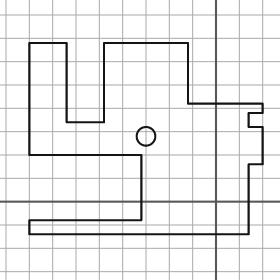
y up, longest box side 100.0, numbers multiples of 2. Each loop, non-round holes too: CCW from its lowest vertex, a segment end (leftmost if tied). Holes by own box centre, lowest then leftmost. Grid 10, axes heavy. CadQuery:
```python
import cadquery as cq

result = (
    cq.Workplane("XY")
    .moveTo(-80.0, -14.0)
    .lineTo(14.0, -14.0)
    .lineTo(14.0, 16.0)
    .lineTo(20.0, 16.0)
    .lineTo(20.0, 32.0)
    .lineTo(14.0, 32.0)
    .lineTo(14.0, 38.0)
    .lineTo(20.0, 38.0)
    .lineTo(20.0, 42.0)
    .lineTo(-12.0, 42.0)
    .lineTo(-12.0, 68.0)
    .lineTo(-48.0, 68.0)
    .lineTo(-48.0, 34.0)
    .lineTo(-64.0, 34.0)
    .lineTo(-64.0, 68.0)
    .lineTo(-80.0, 68.0)
    .lineTo(-80.0, 20.0)
    .lineTo(-32.0, 20.0)
    .lineTo(-32.0, -8.0)
    .lineTo(-80.0, -8.0)
    .close()
    .moveTo(-30.0, 28.0)
    .circle(4.0)
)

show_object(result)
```